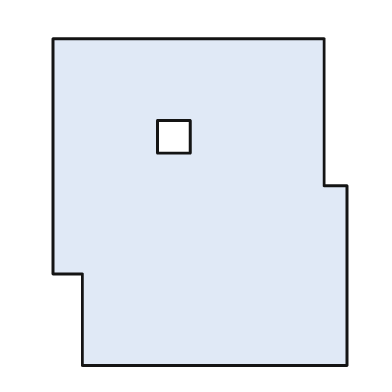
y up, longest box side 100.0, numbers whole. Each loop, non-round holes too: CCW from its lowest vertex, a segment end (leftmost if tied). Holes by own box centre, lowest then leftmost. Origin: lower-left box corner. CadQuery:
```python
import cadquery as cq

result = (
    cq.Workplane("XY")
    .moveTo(9.0, 0.0)
    .lineTo(90.0, 0.0)
    .lineTo(90.0, 55.0)
    .lineTo(83.0, 55.0)
    .lineTo(83.0, 100.0)
    .lineTo(0.0, 100.0)
    .lineTo(0.0, 28.0)
    .lineTo(9.0, 28.0)
    .close()
    .moveTo(32.0, 65.0)
    .lineTo(42.0, 65.0)
    .lineTo(42.0, 75.0)
    .lineTo(32.0, 75.0)
    .close()
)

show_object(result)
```